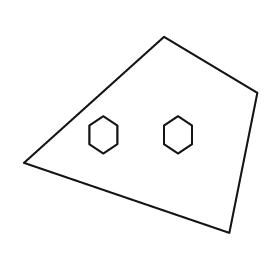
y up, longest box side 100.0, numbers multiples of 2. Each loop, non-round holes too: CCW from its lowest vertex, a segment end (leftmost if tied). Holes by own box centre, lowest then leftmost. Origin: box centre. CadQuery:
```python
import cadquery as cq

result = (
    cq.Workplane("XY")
    .moveTo(38.0, -42.0)
    .lineTo(50.0, 18.0)
    .lineTo(10.0, 42.0)
    .lineTo(-50.0, -12.0)
    .close()
    .moveTo(-16.0, -8.0)
    .lineTo(-10.0, -4.0)
    .lineTo(-10.0, 4.0)
    .lineTo(-16.0, 8.0)
    .lineTo(-22.0, 4.0)
    .lineTo(-22.0, -4.0)
    .close()
    .moveTo(16.0, -8.0)
    .lineTo(22.0, -4.0)
    .lineTo(22.0, 4.0)
    .lineTo(16.0, 8.0)
    .lineTo(10.0, 4.0)
    .lineTo(10.0, -4.0)
    .close()
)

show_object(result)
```